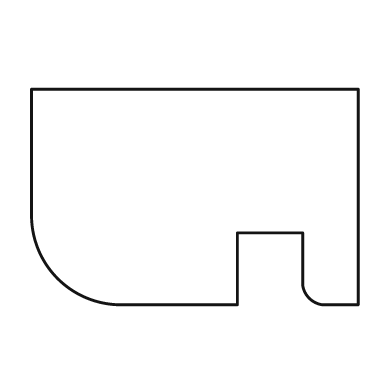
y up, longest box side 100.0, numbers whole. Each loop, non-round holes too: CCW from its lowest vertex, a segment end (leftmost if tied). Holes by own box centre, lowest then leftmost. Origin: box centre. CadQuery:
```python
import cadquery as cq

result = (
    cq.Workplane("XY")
    .moveTo(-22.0, -33.0)
    .lineTo(13.0, -33.0)
    .lineTo(13.0, -11.0)
    .lineTo(33.0, -11.0)
    .lineTo(33.0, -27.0)
    .threePointArc((35.0, -31.0), (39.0, -33.0))
    .lineTo(50.0, -33.0)
    .lineTo(50.0, 33.0)
    .lineTo(-50.0, 33.0)
    .lineTo(-50.0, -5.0)
    .threePointArc((-42.0, -25.0), (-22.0, -33.0))
    .close()
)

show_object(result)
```